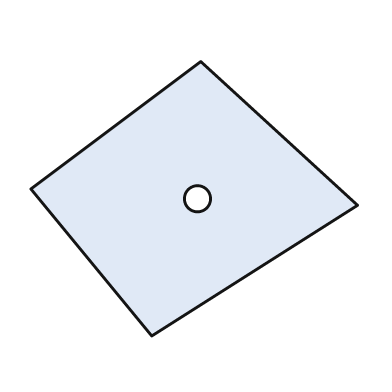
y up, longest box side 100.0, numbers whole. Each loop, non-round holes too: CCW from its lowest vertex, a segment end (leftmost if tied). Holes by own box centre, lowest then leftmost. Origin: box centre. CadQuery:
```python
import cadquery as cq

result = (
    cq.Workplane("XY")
    .moveTo(-13.0, -42.0)
    .lineTo(50.0, -2.0)
    .lineTo(2.0, 42.0)
    .lineTo(-50.0, 3.0)
    .close()
    .moveTo(1.0, 0.0)
    .circle(4.0)
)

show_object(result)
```